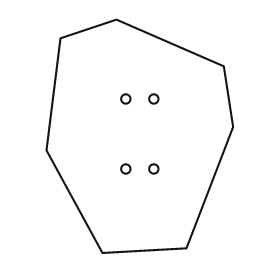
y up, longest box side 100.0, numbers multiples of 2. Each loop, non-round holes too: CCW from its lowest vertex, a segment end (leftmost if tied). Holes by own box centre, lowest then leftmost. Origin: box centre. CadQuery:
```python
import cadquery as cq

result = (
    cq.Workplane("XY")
    .moveTo(-16.0, -50.0)
    .lineTo(20.0, -48.0)
    .lineTo(40.0, 4.0)
    .lineTo(36.0, 30.0)
    .lineTo(-10.0, 50.0)
    .lineTo(-34.0, 42.0)
    .lineTo(-40.0, -6.0)
    .close()
    .moveTo(-6.0, -14.0)
    .circle(2.0)
    .moveTo(6.0, -14.0)
    .circle(2.0)
    .moveTo(-6.0, 16.0)
    .circle(2.0)
    .moveTo(6.0, 16.0)
    .circle(2.0)
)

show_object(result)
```